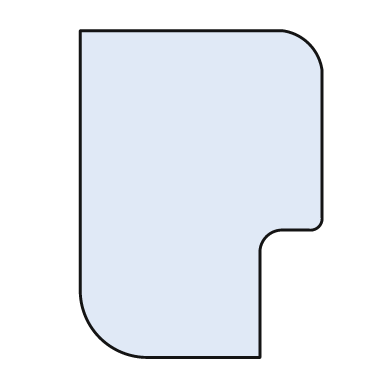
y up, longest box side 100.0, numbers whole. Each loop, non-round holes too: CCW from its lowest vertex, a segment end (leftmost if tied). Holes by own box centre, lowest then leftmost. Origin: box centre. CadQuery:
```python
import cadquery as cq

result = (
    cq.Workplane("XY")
    .moveTo(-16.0, -50.0)
    .lineTo(18.0, -50.0)
    .lineTo(18.0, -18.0)
    .threePointArc((20.0, -13.0), (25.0, -11.0))
    .lineTo(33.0, -11.0)
    .threePointArc((36.0, -10.0), (37.0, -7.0))
    .lineTo(37.0, 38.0)
    .threePointArc((33.0, 46.0), (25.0, 50.0))
    .lineTo(-37.0, 50.0)
    .lineTo(-37.0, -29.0)
    .threePointArc((-31.0, -44.0), (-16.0, -50.0))
    .close()
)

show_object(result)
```